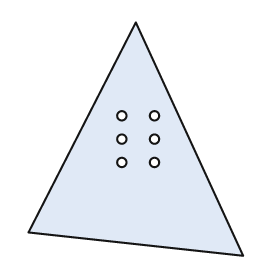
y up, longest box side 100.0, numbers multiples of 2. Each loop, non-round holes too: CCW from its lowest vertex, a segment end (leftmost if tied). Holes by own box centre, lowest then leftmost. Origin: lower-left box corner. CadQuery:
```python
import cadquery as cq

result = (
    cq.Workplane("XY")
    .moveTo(92.0, 0.0)
    .lineTo(46.0, 100.0)
    .lineTo(0.0, 10.0)
    .close()
    .moveTo(40.0, 40.0)
    .circle(2.0)
    .moveTo(54.0, 40.0)
    .circle(2.0)
    .moveTo(40.0, 50.0)
    .circle(2.0)
    .moveTo(54.0, 50.0)
    .circle(2.0)
    .moveTo(40.0, 60.0)
    .circle(2.0)
    .moveTo(54.0, 60.0)
    .circle(2.0)
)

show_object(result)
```